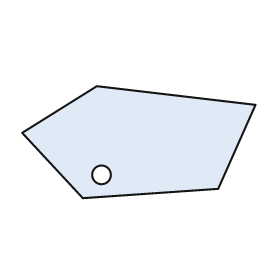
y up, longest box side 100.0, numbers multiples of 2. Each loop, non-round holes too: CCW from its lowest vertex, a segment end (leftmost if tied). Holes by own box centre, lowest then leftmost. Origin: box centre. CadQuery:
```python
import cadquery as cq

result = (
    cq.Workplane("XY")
    .moveTo(-24.0, -24.0)
    .lineTo(34.0, -20.0)
    .lineTo(50.0, 16.0)
    .lineTo(-18.0, 24.0)
    .lineTo(-50.0, 4.0)
    .close()
    .moveTo(-16.0, -14.0)
    .circle(4.0)
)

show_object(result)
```